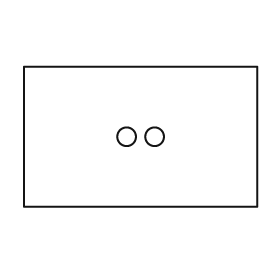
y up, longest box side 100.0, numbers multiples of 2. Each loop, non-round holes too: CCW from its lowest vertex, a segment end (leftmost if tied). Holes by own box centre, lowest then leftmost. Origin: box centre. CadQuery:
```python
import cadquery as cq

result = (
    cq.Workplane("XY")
    .moveTo(-50.0, -30.0)
    .lineTo(50.0, -30.0)
    .lineTo(50.0, 30.0)
    .lineTo(-50.0, 30.0)
    .close()
    .moveTo(-6.0, 0.0)
    .circle(4.0)
    .moveTo(6.0, 0.0)
    .circle(4.0)
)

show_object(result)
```